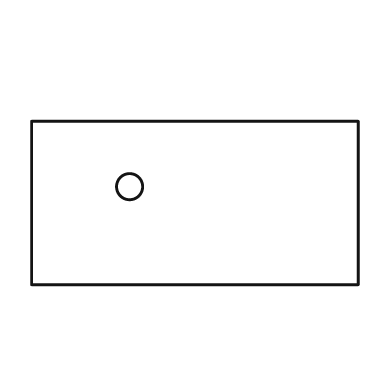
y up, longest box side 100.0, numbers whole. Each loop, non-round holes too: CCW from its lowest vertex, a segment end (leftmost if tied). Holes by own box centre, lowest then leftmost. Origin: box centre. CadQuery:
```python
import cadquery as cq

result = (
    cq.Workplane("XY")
    .moveTo(-50.0, -25.0)
    .lineTo(50.0, -25.0)
    .lineTo(50.0, 25.0)
    .lineTo(-50.0, 25.0)
    .close()
    .moveTo(-20.0, 5.0)
    .circle(4.0)
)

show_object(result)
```